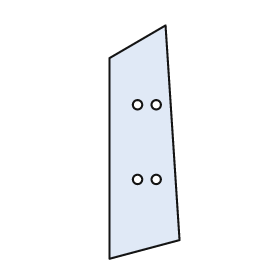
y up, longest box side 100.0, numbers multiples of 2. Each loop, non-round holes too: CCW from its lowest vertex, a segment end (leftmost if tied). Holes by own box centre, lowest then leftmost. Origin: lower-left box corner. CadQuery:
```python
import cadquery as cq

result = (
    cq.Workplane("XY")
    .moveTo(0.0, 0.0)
    .lineTo(30.0, 8.0)
    .lineTo(24.0, 100.0)
    .lineTo(0.0, 86.0)
    .close()
    .moveTo(12.0, 34.0)
    .circle(2.0)
    .moveTo(20.0, 34.0)
    .circle(2.0)
    .moveTo(12.0, 66.0)
    .circle(2.0)
    .moveTo(20.0, 66.0)
    .circle(2.0)
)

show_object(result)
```